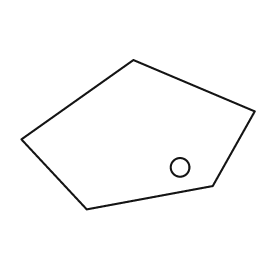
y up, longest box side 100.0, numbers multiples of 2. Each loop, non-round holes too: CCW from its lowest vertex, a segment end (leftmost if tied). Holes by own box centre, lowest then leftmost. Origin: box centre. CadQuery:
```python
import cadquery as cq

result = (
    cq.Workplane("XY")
    .moveTo(-22.0, -32.0)
    .lineTo(32.0, -22.0)
    .lineTo(50.0, 10.0)
    .lineTo(-2.0, 32.0)
    .lineTo(-50.0, -2.0)
    .close()
    .moveTo(18.0, -14.0)
    .circle(4.0)
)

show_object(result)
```